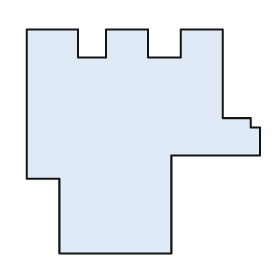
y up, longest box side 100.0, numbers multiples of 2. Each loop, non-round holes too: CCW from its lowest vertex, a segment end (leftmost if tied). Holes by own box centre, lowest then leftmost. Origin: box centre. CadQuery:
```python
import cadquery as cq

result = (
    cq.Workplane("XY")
    .moveTo(-36.0, -48.0)
    .lineTo(12.0, -48.0)
    .lineTo(12.0, -6.0)
    .lineTo(50.0, -6.0)
    .lineTo(50.0, 6.0)
    .lineTo(46.0, 6.0)
    .lineTo(46.0, 10.0)
    .lineTo(34.0, 10.0)
    .lineTo(34.0, 48.0)
    .lineTo(16.0, 48.0)
    .lineTo(16.0, 36.0)
    .lineTo(2.0, 36.0)
    .lineTo(2.0, 48.0)
    .lineTo(-16.0, 48.0)
    .lineTo(-16.0, 36.0)
    .lineTo(-28.0, 36.0)
    .lineTo(-28.0, 48.0)
    .lineTo(-50.0, 48.0)
    .lineTo(-50.0, -16.0)
    .lineTo(-36.0, -16.0)
    .close()
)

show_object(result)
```